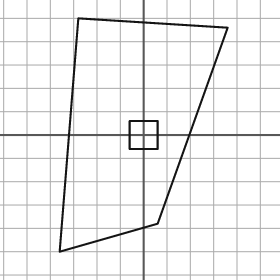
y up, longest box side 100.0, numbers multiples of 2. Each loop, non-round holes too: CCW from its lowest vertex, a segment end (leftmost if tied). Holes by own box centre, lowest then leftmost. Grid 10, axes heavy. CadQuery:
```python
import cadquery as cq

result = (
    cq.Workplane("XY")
    .moveTo(-36.0, -50.0)
    .lineTo(6.0, -38.0)
    .lineTo(36.0, 46.0)
    .lineTo(-28.0, 50.0)
    .close()
    .moveTo(-6.0, -6.0)
    .lineTo(6.0, -6.0)
    .lineTo(6.0, 6.0)
    .lineTo(-6.0, 6.0)
    .close()
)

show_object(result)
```